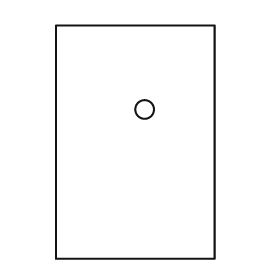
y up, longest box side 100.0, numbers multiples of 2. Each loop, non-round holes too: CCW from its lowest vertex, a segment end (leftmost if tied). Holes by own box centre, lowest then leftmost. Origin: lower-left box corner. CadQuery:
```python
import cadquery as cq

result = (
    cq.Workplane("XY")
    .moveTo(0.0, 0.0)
    .lineTo(68.0, 0.0)
    .lineTo(68.0, 100.0)
    .lineTo(0.0, 100.0)
    .close()
    .moveTo(38.0, 64.0)
    .circle(4.0)
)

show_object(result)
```